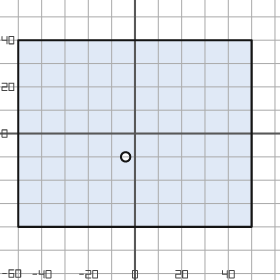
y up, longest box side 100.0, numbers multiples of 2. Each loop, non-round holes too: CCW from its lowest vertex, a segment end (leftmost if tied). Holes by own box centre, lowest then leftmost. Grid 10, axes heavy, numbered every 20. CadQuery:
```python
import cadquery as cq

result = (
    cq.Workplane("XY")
    .moveTo(-50.0, -40.0)
    .lineTo(50.0, -40.0)
    .lineTo(50.0, 40.0)
    .lineTo(-50.0, 40.0)
    .close()
    .moveTo(-4.0, -10.0)
    .circle(2.0)
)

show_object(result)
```